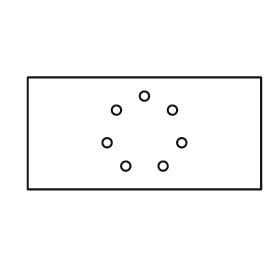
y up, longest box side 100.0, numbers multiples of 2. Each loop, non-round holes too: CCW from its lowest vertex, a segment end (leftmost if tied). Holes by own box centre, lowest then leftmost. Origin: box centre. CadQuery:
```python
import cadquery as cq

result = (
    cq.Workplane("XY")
    .moveTo(-50.0, -24.0)
    .lineTo(50.0, -24.0)
    .lineTo(50.0, 24.0)
    .lineTo(-50.0, 24.0)
    .close()
    .moveTo(-8.0, -14.0)
    .circle(2.0)
    .moveTo(8.0, -14.0)
    .circle(2.0)
    .moveTo(-16.0, -4.0)
    .circle(2.0)
    .moveTo(16.0, -4.0)
    .circle(2.0)
    .moveTo(-12.0, 10.0)
    .circle(2.0)
    .moveTo(12.0, 10.0)
    .circle(2.0)
    .moveTo(0.0, 16.0)
    .circle(2.0)
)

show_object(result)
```